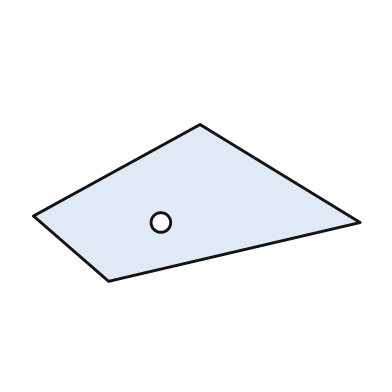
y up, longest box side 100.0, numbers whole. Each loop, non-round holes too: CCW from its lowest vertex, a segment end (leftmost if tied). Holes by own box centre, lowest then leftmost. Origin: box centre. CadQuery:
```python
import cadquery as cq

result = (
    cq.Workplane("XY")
    .moveTo(-27.0, -24.0)
    .lineTo(50.0, -6.0)
    .lineTo(1.0, 24.0)
    .lineTo(-50.0, -4.0)
    .close()
    .moveTo(-11.0, -6.0)
    .circle(3.0)
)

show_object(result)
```